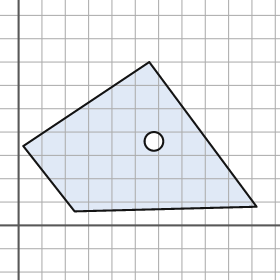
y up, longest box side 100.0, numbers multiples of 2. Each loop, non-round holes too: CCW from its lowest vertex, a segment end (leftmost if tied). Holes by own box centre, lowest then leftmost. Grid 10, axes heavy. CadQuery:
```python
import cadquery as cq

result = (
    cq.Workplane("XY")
    .moveTo(24.0, 6.0)
    .lineTo(102.0, 8.0)
    .lineTo(56.0, 70.0)
    .lineTo(2.0, 34.0)
    .close()
    .moveTo(58.0, 36.0)
    .circle(4.0)
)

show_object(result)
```